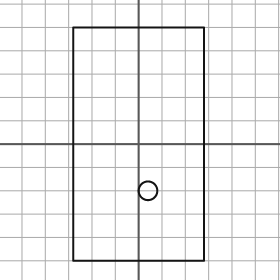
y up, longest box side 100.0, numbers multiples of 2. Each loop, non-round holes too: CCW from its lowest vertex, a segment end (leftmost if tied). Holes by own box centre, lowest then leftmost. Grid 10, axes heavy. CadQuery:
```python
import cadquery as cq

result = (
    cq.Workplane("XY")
    .moveTo(-28.0, -50.0)
    .lineTo(28.0, -50.0)
    .lineTo(28.0, 50.0)
    .lineTo(-28.0, 50.0)
    .close()
    .moveTo(4.0, -20.0)
    .circle(4.0)
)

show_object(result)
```